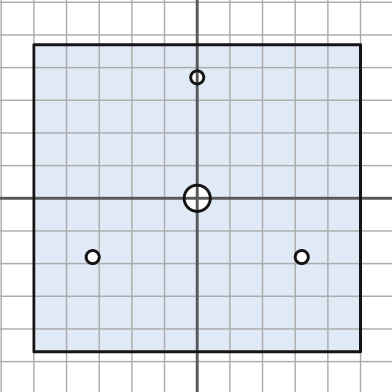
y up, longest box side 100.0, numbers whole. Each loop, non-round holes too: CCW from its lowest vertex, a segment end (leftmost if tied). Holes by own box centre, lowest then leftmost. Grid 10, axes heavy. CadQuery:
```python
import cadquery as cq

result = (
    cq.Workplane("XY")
    .moveTo(-50.0, -47.0)
    .lineTo(50.0, -47.0)
    .lineTo(50.0, 47.0)
    .lineTo(-50.0, 47.0)
    .close()
    .moveTo(-32.0, -18.0)
    .circle(2.0)
    .moveTo(32.0, -18.0)
    .circle(2.0)
    .moveTo(0.0, 0.0)
    .circle(4.0)
    .moveTo(0.0, 37.0)
    .circle(2.0)
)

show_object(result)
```